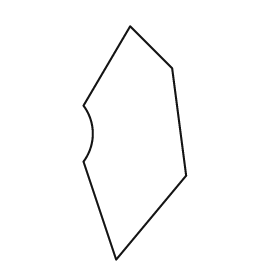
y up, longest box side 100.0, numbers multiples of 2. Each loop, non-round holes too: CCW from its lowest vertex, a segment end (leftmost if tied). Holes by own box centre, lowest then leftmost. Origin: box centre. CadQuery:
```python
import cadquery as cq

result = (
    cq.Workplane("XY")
    .moveTo(-8.0, -50.0)
    .lineTo(22.0, -14.0)
    .lineTo(16.0, 32.0)
    .lineTo(-2.0, 50.0)
    .lineTo(-22.0, 16.0)
    .threePointArc((-18.0, 4.0), (-22.0, -8.0))
    .close()
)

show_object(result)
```